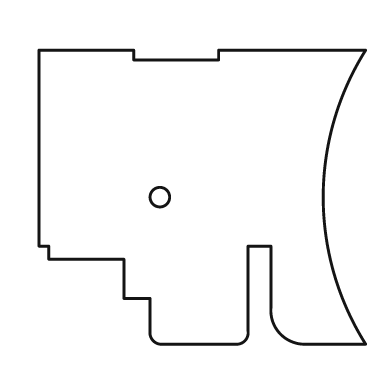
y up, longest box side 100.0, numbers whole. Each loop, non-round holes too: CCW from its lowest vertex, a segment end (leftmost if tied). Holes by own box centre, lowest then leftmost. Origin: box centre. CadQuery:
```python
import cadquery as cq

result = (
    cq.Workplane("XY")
    .moveTo(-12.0, -45.0)
    .lineTo(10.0, -45.0)
    .threePointArc((13.0, -44.0), (14.0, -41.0))
    .lineTo(14.0, -15.0)
    .lineTo(21.0, -15.0)
    .lineTo(21.0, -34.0)
    .threePointArc((24.0, -42.0), (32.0, -45.0))
    .lineTo(50.0, -45.0)
    .threePointArc((37.0, 0.0), (50.0, 45.0))
    .lineTo(5.0, 45.0)
    .lineTo(5.0, 42.0)
    .lineTo(-21.0, 42.0)
    .lineTo(-21.0, 45.0)
    .lineTo(-50.0, 45.0)
    .lineTo(-50.0, -15.0)
    .lineTo(-47.0, -15.0)
    .lineTo(-47.0, -19.0)
    .lineTo(-24.0, -19.0)
    .lineTo(-24.0, -31.0)
    .lineTo(-16.0, -31.0)
    .lineTo(-16.0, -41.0)
    .threePointArc((-15.0, -44.0), (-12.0, -45.0))
    .close()
    .moveTo(-13.0, 0.0)
    .circle(3.0)
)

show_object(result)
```